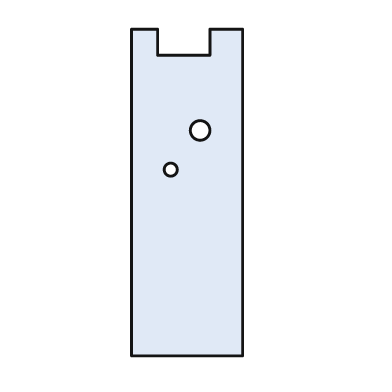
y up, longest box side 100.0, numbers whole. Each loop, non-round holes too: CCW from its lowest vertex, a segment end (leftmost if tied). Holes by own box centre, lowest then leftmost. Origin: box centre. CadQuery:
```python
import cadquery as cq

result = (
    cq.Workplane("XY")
    .moveTo(-17.0, -50.0)
    .lineTo(17.0, -50.0)
    .lineTo(17.0, 50.0)
    .lineTo(7.0, 50.0)
    .lineTo(7.0, 42.0)
    .lineTo(-9.0, 42.0)
    .lineTo(-9.0, 50.0)
    .lineTo(-17.0, 50.0)
    .close()
    .moveTo(-5.0, 7.0)
    .circle(2.0)
    .moveTo(4.0, 19.0)
    .circle(3.0)
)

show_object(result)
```